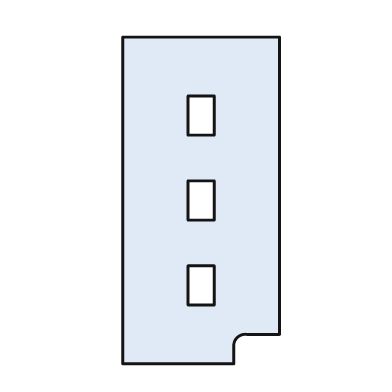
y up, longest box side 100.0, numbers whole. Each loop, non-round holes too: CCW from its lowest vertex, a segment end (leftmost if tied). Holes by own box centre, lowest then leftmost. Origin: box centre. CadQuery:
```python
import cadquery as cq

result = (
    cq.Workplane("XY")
    .moveTo(-24.0, -50.0)
    .lineTo(10.0, -50.0)
    .lineTo(10.0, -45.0)
    .threePointArc((11.0, -42.0), (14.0, -41.0))
    .lineTo(24.0, -41.0)
    .lineTo(24.0, 50.0)
    .lineTo(-24.0, 50.0)
    .close()
    .moveTo(-4.0, -32.0)
    .lineTo(4.0, -32.0)
    .lineTo(4.0, -20.0)
    .lineTo(-4.0, -20.0)
    .close()
    .moveTo(-4.0, -6.0)
    .lineTo(4.0, -6.0)
    .lineTo(4.0, 6.0)
    .lineTo(-4.0, 6.0)
    .close()
    .moveTo(-4.0, 20.0)
    .lineTo(4.0, 20.0)
    .lineTo(4.0, 32.0)
    .lineTo(-4.0, 32.0)
    .close()
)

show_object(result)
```